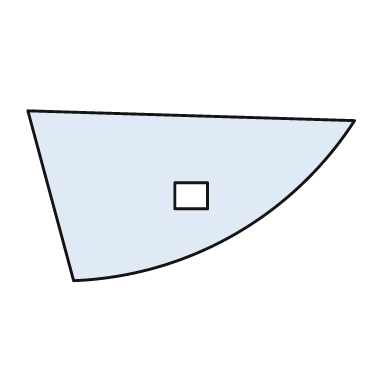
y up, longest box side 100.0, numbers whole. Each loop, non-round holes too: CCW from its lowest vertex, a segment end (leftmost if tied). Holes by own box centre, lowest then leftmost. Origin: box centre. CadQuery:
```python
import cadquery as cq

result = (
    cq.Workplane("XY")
    .moveTo(-36.0, -26.0)
    .threePointArc((13.0, -12.0), (50.0, 23.0))
    .lineTo(-50.0, 26.0)
    .close()
    .moveTo(-5.0, -4.0)
    .lineTo(5.0, -4.0)
    .lineTo(5.0, 4.0)
    .lineTo(-5.0, 4.0)
    .close()
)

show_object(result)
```